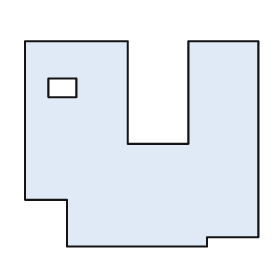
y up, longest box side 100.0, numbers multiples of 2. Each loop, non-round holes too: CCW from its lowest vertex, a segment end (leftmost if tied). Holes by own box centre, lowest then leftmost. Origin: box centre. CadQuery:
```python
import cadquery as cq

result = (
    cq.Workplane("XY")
    .moveTo(-32.0, -44.0)
    .lineTo(28.0, -44.0)
    .lineTo(28.0, -40.0)
    .lineTo(50.0, -40.0)
    .lineTo(50.0, 44.0)
    .lineTo(20.0, 44.0)
    .lineTo(20.0, 0.0)
    .lineTo(-6.0, 0.0)
    .lineTo(-6.0, 44.0)
    .lineTo(-50.0, 44.0)
    .lineTo(-50.0, -24.0)
    .lineTo(-32.0, -24.0)
    .close()
    .moveTo(-40.0, 20.0)
    .lineTo(-28.0, 20.0)
    .lineTo(-28.0, 28.0)
    .lineTo(-40.0, 28.0)
    .close()
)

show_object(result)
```